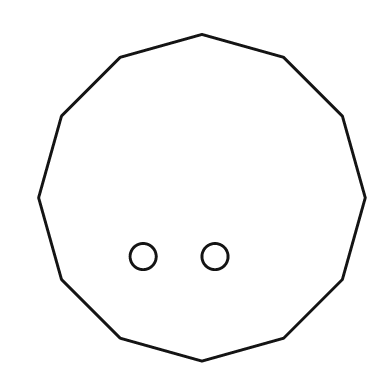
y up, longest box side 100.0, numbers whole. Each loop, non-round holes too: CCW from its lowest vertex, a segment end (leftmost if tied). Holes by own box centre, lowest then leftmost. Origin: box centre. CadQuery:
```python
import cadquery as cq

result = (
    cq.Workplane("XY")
    .moveTo(0.0, -50.0)
    .lineTo(25.0, -43.0)
    .lineTo(43.0, -25.0)
    .lineTo(50.0, 0.0)
    .lineTo(43.0, 25.0)
    .lineTo(25.0, 43.0)
    .lineTo(0.0, 50.0)
    .lineTo(-25.0, 43.0)
    .lineTo(-43.0, 25.0)
    .lineTo(-50.0, 0.0)
    .lineTo(-43.0, -25.0)
    .lineTo(-25.0, -43.0)
    .close()
    .moveTo(-18.0, -18.0)
    .circle(4.0)
    .moveTo(4.0, -18.0)
    .circle(4.0)
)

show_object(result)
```